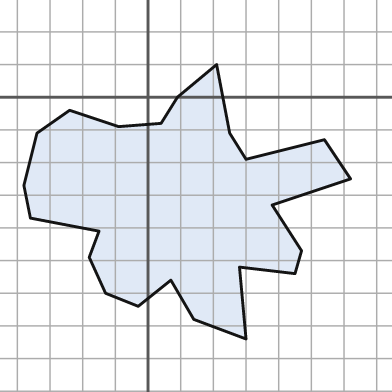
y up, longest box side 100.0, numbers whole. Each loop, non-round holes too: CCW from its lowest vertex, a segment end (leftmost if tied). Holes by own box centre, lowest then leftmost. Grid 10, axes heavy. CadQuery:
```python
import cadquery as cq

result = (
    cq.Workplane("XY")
    .moveTo(30.0, -74.0)
    .lineTo(28.0, -52.0)
    .lineTo(45.0, -54.0)
    .lineTo(47.0, -47.0)
    .lineTo(38.0, -33.0)
    .lineTo(62.0, -25.0)
    .lineTo(54.0, -13.0)
    .lineTo(30.0, -19.0)
    .lineTo(25.0, -11.0)
    .lineTo(21.0, 10.0)
    .lineTo(9.0, 0.0)
    .lineTo(4.0, -8.0)
    .lineTo(-9.0, -9.0)
    .lineTo(-24.0, -4.0)
    .lineTo(-34.0, -11.0)
    .lineTo(-38.0, -27.0)
    .lineTo(-36.0, -37.0)
    .lineTo(-15.0, -41.0)
    .lineTo(-18.0, -49.0)
    .lineTo(-13.0, -60.0)
    .lineTo(-3.0, -64.0)
    .lineTo(7.0, -56.0)
    .lineTo(14.0, -68.0)
    .close()
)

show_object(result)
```